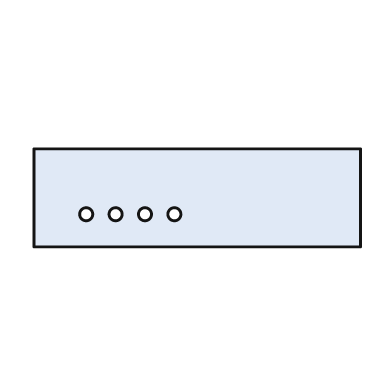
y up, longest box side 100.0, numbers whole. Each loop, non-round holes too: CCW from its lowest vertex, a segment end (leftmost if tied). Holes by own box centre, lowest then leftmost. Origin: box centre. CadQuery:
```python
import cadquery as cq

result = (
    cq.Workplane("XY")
    .moveTo(-50.0, -15.0)
    .lineTo(50.0, -15.0)
    .lineTo(50.0, 15.0)
    .lineTo(-50.0, 15.0)
    .close()
    .moveTo(-34.0, -5.0)
    .circle(2.0)
    .moveTo(-25.0, -5.0)
    .circle(2.0)
    .moveTo(-16.0, -5.0)
    .circle(2.0)
    .moveTo(-7.0, -5.0)
    .circle(2.0)
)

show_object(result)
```